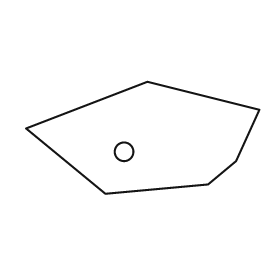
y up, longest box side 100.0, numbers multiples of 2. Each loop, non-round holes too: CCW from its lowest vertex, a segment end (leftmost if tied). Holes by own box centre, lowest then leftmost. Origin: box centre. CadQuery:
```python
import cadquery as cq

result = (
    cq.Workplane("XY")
    .moveTo(-16.0, -24.0)
    .lineTo(28.0, -20.0)
    .lineTo(40.0, -10.0)
    .lineTo(50.0, 12.0)
    .lineTo(2.0, 24.0)
    .lineTo(-50.0, 4.0)
    .close()
    .moveTo(-8.0, -6.0)
    .circle(4.0)
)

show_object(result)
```